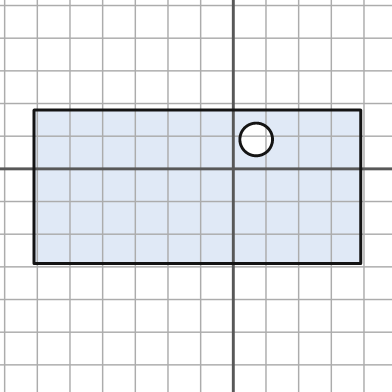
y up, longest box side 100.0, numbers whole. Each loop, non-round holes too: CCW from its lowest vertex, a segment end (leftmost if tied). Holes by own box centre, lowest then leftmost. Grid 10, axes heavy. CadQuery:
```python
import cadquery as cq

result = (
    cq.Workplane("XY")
    .moveTo(-61.0, -29.0)
    .lineTo(39.0, -29.0)
    .lineTo(39.0, 18.0)
    .lineTo(-61.0, 18.0)
    .close()
    .moveTo(7.0, 9.0)
    .circle(5.0)
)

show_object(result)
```